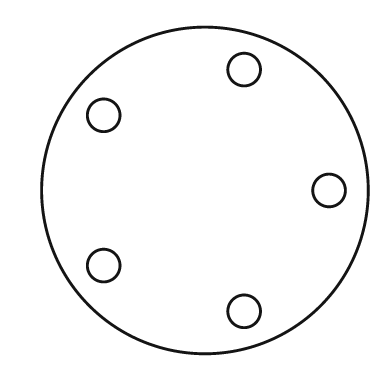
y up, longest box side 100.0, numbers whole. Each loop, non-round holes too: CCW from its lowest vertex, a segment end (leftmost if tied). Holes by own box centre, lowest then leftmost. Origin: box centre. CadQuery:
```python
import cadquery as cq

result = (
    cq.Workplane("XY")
    .moveTo(0.0, 0.0)
    .circle(50.0)
    .moveTo(12.0, -37.0)
    .circle(5.0)
    .moveTo(-31.0, -23.0)
    .circle(5.0)
    .moveTo(38.0, 0.0)
    .circle(5.0)
    .moveTo(-31.0, 23.0)
    .circle(5.0)
    .moveTo(12.0, 37.0)
    .circle(5.0)
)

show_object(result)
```